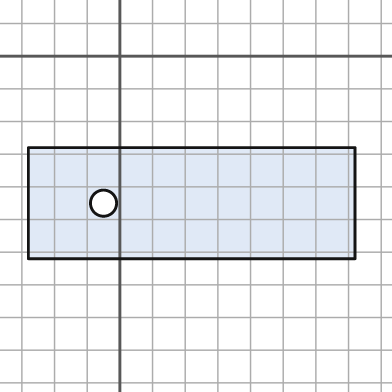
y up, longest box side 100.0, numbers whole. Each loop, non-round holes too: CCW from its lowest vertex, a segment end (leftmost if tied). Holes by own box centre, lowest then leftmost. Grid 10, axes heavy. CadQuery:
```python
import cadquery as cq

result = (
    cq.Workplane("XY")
    .moveTo(-28.0, -62.0)
    .lineTo(72.0, -62.0)
    .lineTo(72.0, -28.0)
    .lineTo(-28.0, -28.0)
    .close()
    .moveTo(-5.0, -45.0)
    .circle(4.0)
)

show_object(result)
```